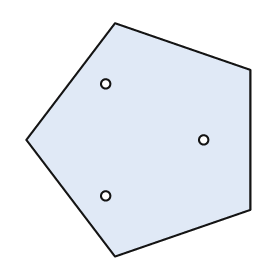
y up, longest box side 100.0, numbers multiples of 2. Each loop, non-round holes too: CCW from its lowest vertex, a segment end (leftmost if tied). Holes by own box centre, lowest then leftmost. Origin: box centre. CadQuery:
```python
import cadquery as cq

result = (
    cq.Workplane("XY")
    .moveTo(-10.0, -50.0)
    .lineTo(48.0, -30.0)
    .lineTo(48.0, 30.0)
    .lineTo(-10.0, 50.0)
    .lineTo(-48.0, 0.0)
    .close()
    .moveTo(-14.0, -24.0)
    .circle(2.0)
    .moveTo(28.0, 0.0)
    .circle(2.0)
    .moveTo(-14.0, 24.0)
    .circle(2.0)
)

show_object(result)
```